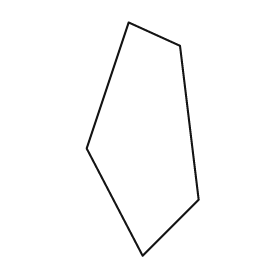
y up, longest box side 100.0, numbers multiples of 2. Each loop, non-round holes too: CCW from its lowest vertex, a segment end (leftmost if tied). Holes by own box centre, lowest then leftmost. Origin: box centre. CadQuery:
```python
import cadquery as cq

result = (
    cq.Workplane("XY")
    .moveTo(0.0, -50.0)
    .lineTo(24.0, -26.0)
    .lineTo(16.0, 40.0)
    .lineTo(-6.0, 50.0)
    .lineTo(-24.0, -4.0)
    .close()
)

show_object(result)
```